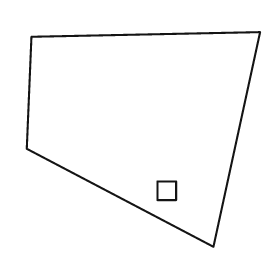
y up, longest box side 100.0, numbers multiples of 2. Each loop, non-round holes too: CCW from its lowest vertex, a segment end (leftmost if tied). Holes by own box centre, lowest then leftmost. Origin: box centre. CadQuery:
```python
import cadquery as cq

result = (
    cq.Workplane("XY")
    .moveTo(30.0, -46.0)
    .lineTo(50.0, 46.0)
    .lineTo(-48.0, 44.0)
    .lineTo(-50.0, -4.0)
    .close()
    .moveTo(6.0, -26.0)
    .lineTo(14.0, -26.0)
    .lineTo(14.0, -18.0)
    .lineTo(6.0, -18.0)
    .close()
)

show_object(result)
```